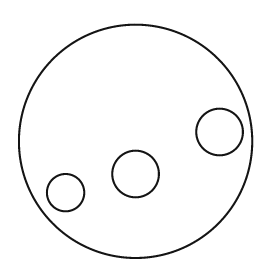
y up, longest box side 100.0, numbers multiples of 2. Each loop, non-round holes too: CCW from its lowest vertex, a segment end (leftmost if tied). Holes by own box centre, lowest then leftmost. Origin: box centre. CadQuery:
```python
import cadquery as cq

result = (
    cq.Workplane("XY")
    .moveTo(0.0, 0.0)
    .circle(50.0)
    .moveTo(-30.0, -22.0)
    .circle(8.0)
    .moveTo(0.0, -14.0)
    .circle(10.0)
    .moveTo(36.0, 4.0)
    .circle(10.0)
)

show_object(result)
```